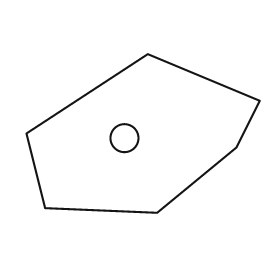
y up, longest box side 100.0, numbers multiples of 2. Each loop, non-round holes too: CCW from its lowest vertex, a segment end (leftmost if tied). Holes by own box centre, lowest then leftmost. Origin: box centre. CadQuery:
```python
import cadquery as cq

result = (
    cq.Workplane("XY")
    .moveTo(6.0, -34.0)
    .lineTo(40.0, -6.0)
    .lineTo(50.0, 14.0)
    .lineTo(2.0, 34.0)
    .lineTo(-50.0, 0.0)
    .lineTo(-42.0, -32.0)
    .close()
    .moveTo(-8.0, -2.0)
    .circle(6.0)
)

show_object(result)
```